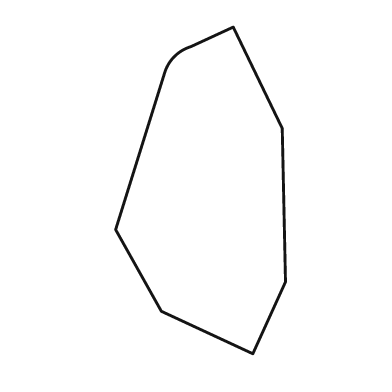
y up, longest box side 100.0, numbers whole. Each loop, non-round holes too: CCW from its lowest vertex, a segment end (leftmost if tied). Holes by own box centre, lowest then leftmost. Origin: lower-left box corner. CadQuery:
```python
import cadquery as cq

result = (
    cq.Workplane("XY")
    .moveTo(42.0, 0.0)
    .lineTo(52.0, 22.0)
    .lineTo(51.0, 69.0)
    .lineTo(36.0, 100.0)
    .lineTo(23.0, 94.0)
    .threePointArc((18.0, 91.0), (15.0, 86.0))
    .lineTo(0.0, 38.0)
    .lineTo(14.0, 13.0)
    .close()
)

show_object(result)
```